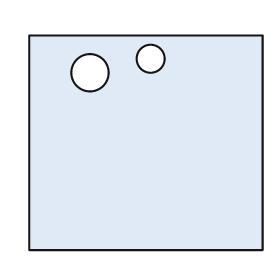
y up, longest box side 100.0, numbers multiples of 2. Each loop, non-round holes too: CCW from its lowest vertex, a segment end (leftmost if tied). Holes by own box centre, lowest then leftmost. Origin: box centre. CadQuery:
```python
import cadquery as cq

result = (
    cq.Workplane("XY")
    .moveTo(-50.0, -46.0)
    .lineTo(50.0, -46.0)
    .lineTo(50.0, 46.0)
    .lineTo(-50.0, 46.0)
    .close()
    .moveTo(-24.0, 30.0)
    .circle(8.0)
    .moveTo(2.0, 36.0)
    .circle(6.0)
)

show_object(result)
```